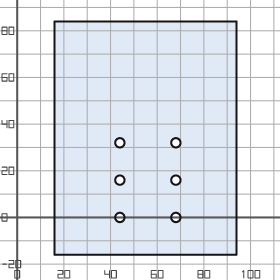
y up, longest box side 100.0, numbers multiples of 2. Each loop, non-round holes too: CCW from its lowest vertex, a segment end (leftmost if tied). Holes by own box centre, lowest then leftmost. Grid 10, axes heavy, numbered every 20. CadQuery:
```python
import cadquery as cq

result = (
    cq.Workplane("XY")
    .moveTo(16.0, -16.0)
    .lineTo(94.0, -16.0)
    .lineTo(94.0, 84.0)
    .lineTo(16.0, 84.0)
    .close()
    .moveTo(44.0, 0.0)
    .circle(2.0)
    .moveTo(68.0, 0.0)
    .circle(2.0)
    .moveTo(44.0, 16.0)
    .circle(2.0)
    .moveTo(68.0, 16.0)
    .circle(2.0)
    .moveTo(44.0, 32.0)
    .circle(2.0)
    .moveTo(68.0, 32.0)
    .circle(2.0)
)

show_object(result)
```